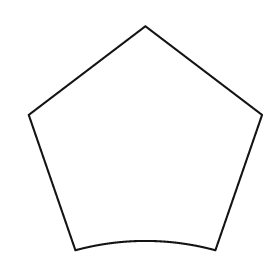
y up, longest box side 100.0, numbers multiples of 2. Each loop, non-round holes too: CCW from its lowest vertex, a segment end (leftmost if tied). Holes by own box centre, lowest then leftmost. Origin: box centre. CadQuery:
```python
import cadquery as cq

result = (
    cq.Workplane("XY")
    .moveTo(-30.0, -48.0)
    .threePointArc((0.0, -44.0), (30.0, -48.0))
    .lineTo(50.0, 10.0)
    .lineTo(0.0, 48.0)
    .lineTo(-50.0, 10.0)
    .close()
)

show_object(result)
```